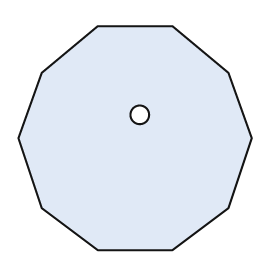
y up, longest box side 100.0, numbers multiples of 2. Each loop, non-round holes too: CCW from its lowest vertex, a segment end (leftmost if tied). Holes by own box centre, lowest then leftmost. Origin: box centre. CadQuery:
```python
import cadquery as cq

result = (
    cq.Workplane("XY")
    .moveTo(-16.0, -48.0)
    .lineTo(16.0, -48.0)
    .lineTo(40.0, -30.0)
    .lineTo(50.0, 0.0)
    .lineTo(40.0, 28.0)
    .lineTo(16.0, 48.0)
    .lineTo(-16.0, 48.0)
    .lineTo(-40.0, 28.0)
    .lineTo(-50.0, 0.0)
    .lineTo(-40.0, -30.0)
    .close()
    .moveTo(2.0, 10.0)
    .circle(4.0)
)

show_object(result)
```